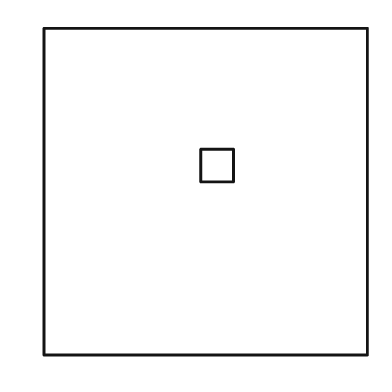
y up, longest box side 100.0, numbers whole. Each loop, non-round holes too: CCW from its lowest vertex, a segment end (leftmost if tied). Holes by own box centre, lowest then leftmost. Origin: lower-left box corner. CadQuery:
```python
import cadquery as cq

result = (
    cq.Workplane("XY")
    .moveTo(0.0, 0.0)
    .lineTo(99.0, 0.0)
    .lineTo(99.0, 100.0)
    .lineTo(0.0, 100.0)
    .close()
    .moveTo(48.0, 53.0)
    .lineTo(58.0, 53.0)
    .lineTo(58.0, 63.0)
    .lineTo(48.0, 63.0)
    .close()
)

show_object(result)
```